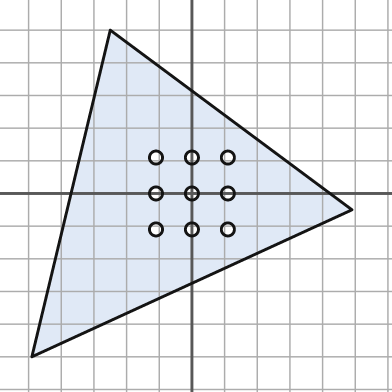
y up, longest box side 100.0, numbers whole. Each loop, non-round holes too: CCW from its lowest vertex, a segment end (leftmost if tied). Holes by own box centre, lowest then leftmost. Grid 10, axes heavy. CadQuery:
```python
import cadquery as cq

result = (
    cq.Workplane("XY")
    .moveTo(-49.0, -50.0)
    .lineTo(49.0, -5.0)
    .lineTo(-25.0, 50.0)
    .close()
    .moveTo(-11.0, -11.0)
    .circle(2.0)
    .moveTo(0.0, -11.0)
    .circle(2.0)
    .moveTo(11.0, -11.0)
    .circle(2.0)
    .moveTo(-11.0, 0.0)
    .circle(2.0)
    .moveTo(0.0, 0.0)
    .circle(2.0)
    .moveTo(11.0, 0.0)
    .circle(2.0)
    .moveTo(-11.0, 11.0)
    .circle(2.0)
    .moveTo(0.0, 11.0)
    .circle(2.0)
    .moveTo(11.0, 11.0)
    .circle(2.0)
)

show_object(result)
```